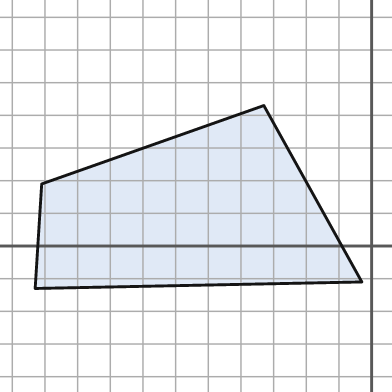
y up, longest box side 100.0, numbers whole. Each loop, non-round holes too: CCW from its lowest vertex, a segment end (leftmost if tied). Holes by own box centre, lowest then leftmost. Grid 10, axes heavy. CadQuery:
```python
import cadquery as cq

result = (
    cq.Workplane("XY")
    .moveTo(-103.0, -13.0)
    .lineTo(-3.0, -11.0)
    .lineTo(-33.0, 43.0)
    .lineTo(-101.0, 19.0)
    .close()
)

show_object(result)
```